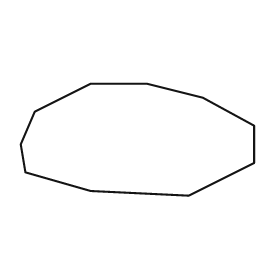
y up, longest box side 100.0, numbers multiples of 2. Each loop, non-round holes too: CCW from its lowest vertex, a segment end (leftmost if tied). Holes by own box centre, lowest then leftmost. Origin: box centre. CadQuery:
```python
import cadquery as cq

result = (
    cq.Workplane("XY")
    .moveTo(22.0, -24.0)
    .lineTo(50.0, -10.0)
    .lineTo(50.0, 6.0)
    .lineTo(28.0, 18.0)
    .lineTo(4.0, 24.0)
    .lineTo(-20.0, 24.0)
    .lineTo(-44.0, 12.0)
    .lineTo(-50.0, -2.0)
    .lineTo(-48.0, -14.0)
    .lineTo(-20.0, -22.0)
    .close()
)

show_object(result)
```